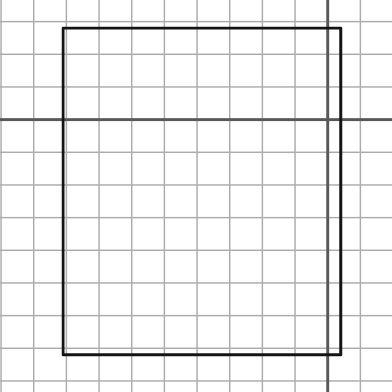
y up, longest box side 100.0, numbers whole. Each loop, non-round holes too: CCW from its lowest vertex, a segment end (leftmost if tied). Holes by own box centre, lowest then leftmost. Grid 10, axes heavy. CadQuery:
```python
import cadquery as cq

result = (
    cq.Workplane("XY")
    .moveTo(-81.0, -72.0)
    .lineTo(4.0, -72.0)
    .lineTo(4.0, 28.0)
    .lineTo(-81.0, 28.0)
    .close()
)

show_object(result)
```